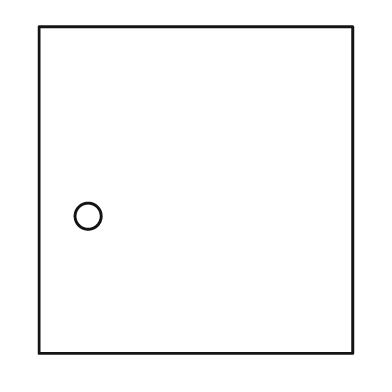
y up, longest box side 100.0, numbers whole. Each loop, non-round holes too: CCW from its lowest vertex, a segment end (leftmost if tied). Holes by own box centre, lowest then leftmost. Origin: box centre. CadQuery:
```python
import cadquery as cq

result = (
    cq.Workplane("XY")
    .moveTo(-48.0, -50.0)
    .lineTo(48.0, -50.0)
    .lineTo(48.0, 50.0)
    .lineTo(-48.0, 50.0)
    .close()
    .moveTo(-33.0, -8.0)
    .circle(4.0)
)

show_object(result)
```